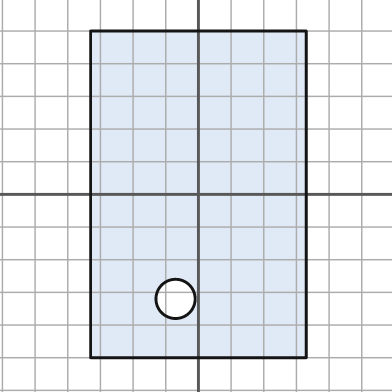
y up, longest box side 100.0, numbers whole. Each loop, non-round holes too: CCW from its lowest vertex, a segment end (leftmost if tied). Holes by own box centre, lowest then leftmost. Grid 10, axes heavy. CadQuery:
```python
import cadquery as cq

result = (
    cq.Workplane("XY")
    .moveTo(-33.0, -50.0)
    .lineTo(33.0, -50.0)
    .lineTo(33.0, 50.0)
    .lineTo(-33.0, 50.0)
    .close()
    .moveTo(-7.0, -32.0)
    .circle(6.0)
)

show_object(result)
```